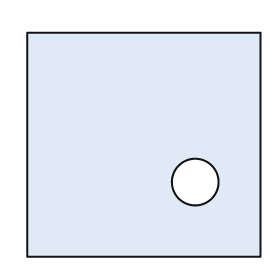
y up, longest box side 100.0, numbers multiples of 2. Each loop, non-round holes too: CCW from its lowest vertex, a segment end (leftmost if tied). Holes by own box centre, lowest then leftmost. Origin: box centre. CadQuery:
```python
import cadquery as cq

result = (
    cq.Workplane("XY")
    .moveTo(-50.0, -48.0)
    .lineTo(50.0, -48.0)
    .lineTo(50.0, 48.0)
    .lineTo(-50.0, 48.0)
    .close()
    .moveTo(22.0, -16.0)
    .circle(10.0)
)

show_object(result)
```